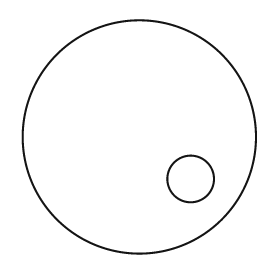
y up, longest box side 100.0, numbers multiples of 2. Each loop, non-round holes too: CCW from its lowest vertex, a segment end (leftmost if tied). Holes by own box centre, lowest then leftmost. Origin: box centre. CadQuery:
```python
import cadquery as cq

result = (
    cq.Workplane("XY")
    .moveTo(0.0, 0.0)
    .circle(50.0)
    .moveTo(22.0, -18.0)
    .circle(10.0)
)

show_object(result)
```